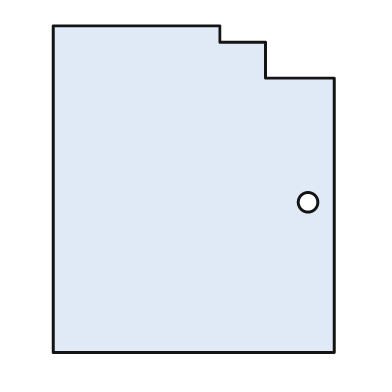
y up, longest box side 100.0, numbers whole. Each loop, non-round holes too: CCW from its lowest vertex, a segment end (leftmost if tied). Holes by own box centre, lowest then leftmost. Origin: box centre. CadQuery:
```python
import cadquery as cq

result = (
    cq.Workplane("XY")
    .moveTo(-43.0, -50.0)
    .lineTo(43.0, -50.0)
    .lineTo(43.0, 34.0)
    .lineTo(22.0, 34.0)
    .lineTo(22.0, 45.0)
    .lineTo(8.0, 45.0)
    .lineTo(8.0, 50.0)
    .lineTo(-43.0, 50.0)
    .close()
    .moveTo(35.0, -4.0)
    .circle(3.0)
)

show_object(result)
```